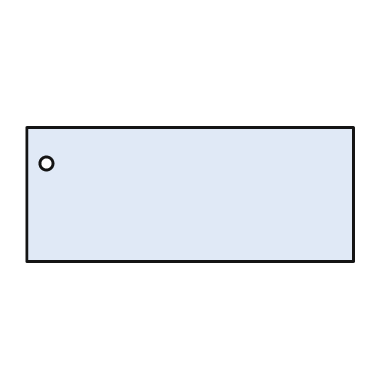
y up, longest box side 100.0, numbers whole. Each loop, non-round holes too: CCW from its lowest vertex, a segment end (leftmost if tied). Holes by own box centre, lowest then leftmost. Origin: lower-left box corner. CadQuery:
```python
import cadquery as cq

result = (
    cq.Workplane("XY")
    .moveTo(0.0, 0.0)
    .lineTo(100.0, 0.0)
    .lineTo(100.0, 41.0)
    .lineTo(0.0, 41.0)
    .close()
    .moveTo(6.0, 30.0)
    .circle(2.0)
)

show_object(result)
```